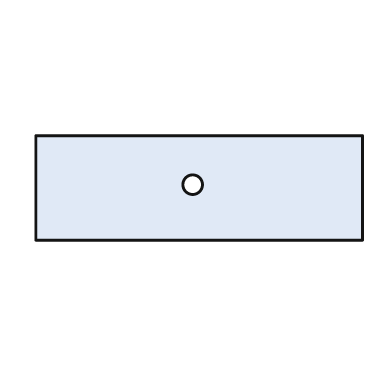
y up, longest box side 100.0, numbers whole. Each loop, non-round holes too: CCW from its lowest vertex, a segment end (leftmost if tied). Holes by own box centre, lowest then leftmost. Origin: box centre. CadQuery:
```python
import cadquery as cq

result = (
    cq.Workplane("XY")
    .moveTo(-50.0, -16.0)
    .lineTo(50.0, -16.0)
    .lineTo(50.0, 16.0)
    .lineTo(-50.0, 16.0)
    .close()
    .moveTo(-2.0, 1.0)
    .circle(3.0)
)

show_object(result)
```